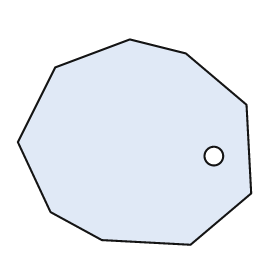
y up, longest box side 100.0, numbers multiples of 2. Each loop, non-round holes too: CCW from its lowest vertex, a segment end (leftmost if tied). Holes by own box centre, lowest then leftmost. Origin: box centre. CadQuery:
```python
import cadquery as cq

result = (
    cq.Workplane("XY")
    .moveTo(24.0, -44.0)
    .lineTo(50.0, -22.0)
    .lineTo(48.0, 16.0)
    .lineTo(22.0, 38.0)
    .lineTo(-2.0, 44.0)
    .lineTo(-34.0, 32.0)
    .lineTo(-50.0, 0.0)
    .lineTo(-36.0, -30.0)
    .lineTo(-14.0, -42.0)
    .close()
    .moveTo(34.0, -6.0)
    .circle(4.0)
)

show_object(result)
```